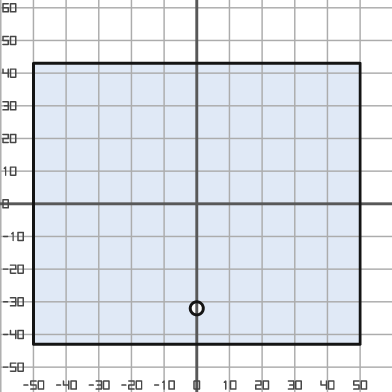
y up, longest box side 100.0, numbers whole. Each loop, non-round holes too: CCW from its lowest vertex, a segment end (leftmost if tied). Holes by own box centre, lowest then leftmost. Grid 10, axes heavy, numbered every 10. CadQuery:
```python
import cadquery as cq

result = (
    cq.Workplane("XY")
    .moveTo(-50.0, -43.0)
    .lineTo(50.0, -43.0)
    .lineTo(50.0, 43.0)
    .lineTo(-50.0, 43.0)
    .close()
    .moveTo(0.0, -32.0)
    .circle(2.0)
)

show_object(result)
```